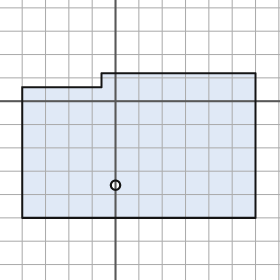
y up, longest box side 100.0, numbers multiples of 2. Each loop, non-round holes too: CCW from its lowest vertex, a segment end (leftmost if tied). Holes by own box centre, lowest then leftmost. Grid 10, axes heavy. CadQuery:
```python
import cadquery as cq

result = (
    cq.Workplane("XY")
    .moveTo(-40.0, -50.0)
    .lineTo(60.0, -50.0)
    .lineTo(60.0, 12.0)
    .lineTo(-6.0, 12.0)
    .lineTo(-6.0, 6.0)
    .lineTo(-40.0, 6.0)
    .close()
    .moveTo(0.0, -36.0)
    .circle(2.0)
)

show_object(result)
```